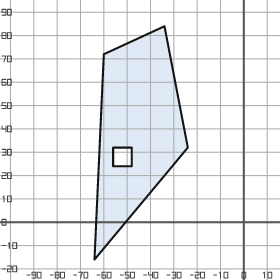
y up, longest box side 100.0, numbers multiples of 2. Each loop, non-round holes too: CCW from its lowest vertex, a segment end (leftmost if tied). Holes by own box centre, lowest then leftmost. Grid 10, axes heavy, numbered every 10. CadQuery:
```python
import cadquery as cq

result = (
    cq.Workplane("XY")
    .moveTo(-64.0, -16.0)
    .lineTo(-24.0, 32.0)
    .lineTo(-34.0, 84.0)
    .lineTo(-60.0, 72.0)
    .close()
    .moveTo(-56.0, 24.0)
    .lineTo(-48.0, 24.0)
    .lineTo(-48.0, 32.0)
    .lineTo(-56.0, 32.0)
    .close()
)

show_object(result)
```